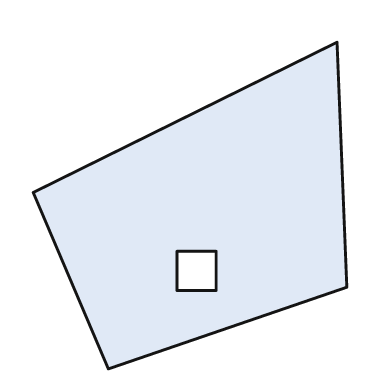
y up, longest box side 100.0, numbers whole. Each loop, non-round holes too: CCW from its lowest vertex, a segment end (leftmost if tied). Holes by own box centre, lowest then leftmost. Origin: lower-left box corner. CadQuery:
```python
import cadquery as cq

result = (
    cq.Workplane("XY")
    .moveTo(23.0, 0.0)
    .lineTo(96.0, 25.0)
    .lineTo(93.0, 100.0)
    .lineTo(0.0, 54.0)
    .close()
    .moveTo(44.0, 24.0)
    .lineTo(56.0, 24.0)
    .lineTo(56.0, 36.0)
    .lineTo(44.0, 36.0)
    .close()
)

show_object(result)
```